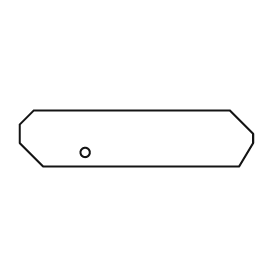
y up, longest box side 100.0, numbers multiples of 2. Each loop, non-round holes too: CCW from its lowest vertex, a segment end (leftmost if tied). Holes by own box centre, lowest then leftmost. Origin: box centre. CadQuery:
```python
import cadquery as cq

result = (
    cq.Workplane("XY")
    .moveTo(-40.0, -12.0)
    .lineTo(44.0, -12.0)
    .lineTo(50.0, -2.0)
    .lineTo(50.0, 2.0)
    .lineTo(40.0, 12.0)
    .lineTo(-44.0, 12.0)
    .lineTo(-50.0, 6.0)
    .lineTo(-50.0, -2.0)
    .close()
    .moveTo(-22.0, -6.0)
    .circle(2.0)
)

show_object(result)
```